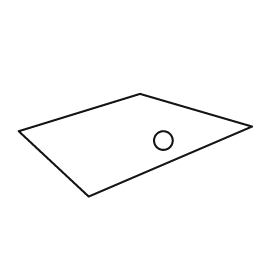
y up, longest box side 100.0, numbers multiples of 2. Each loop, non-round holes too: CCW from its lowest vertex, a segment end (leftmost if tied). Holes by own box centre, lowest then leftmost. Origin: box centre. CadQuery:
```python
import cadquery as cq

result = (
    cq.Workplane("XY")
    .moveTo(-20.0, -22.0)
    .lineTo(50.0, 8.0)
    .lineTo(2.0, 22.0)
    .lineTo(-50.0, 6.0)
    .close()
    .moveTo(12.0, 2.0)
    .circle(4.0)
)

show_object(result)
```